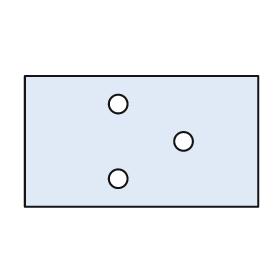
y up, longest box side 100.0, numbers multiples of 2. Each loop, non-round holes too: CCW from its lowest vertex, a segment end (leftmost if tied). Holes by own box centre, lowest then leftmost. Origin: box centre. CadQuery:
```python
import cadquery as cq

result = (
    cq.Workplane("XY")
    .moveTo(-50.0, -28.0)
    .lineTo(50.0, -28.0)
    .lineTo(50.0, 28.0)
    .lineTo(-50.0, 28.0)
    .close()
    .moveTo(-10.0, -16.0)
    .circle(4.0)
    .moveTo(18.0, 0.0)
    .circle(4.0)
    .moveTo(-10.0, 16.0)
    .circle(4.0)
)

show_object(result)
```